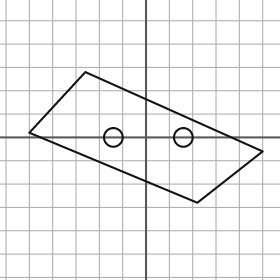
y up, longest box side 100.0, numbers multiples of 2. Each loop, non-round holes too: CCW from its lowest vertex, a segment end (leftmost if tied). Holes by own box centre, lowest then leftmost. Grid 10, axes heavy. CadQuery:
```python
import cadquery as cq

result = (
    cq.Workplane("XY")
    .moveTo(22.0, -28.0)
    .lineTo(50.0, -6.0)
    .lineTo(-26.0, 28.0)
    .lineTo(-50.0, 2.0)
    .close()
    .moveTo(-14.0, 0.0)
    .circle(4.0)
    .moveTo(16.0, 0.0)
    .circle(4.0)
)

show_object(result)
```